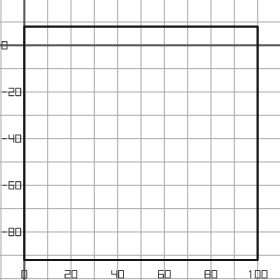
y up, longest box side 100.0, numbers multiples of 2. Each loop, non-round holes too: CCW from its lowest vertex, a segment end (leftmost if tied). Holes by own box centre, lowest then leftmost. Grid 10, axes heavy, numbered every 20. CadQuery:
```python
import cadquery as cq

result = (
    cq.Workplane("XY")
    .moveTo(0.0, -92.0)
    .lineTo(100.0, -92.0)
    .lineTo(100.0, 8.0)
    .lineTo(0.0, 8.0)
    .close()
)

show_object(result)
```